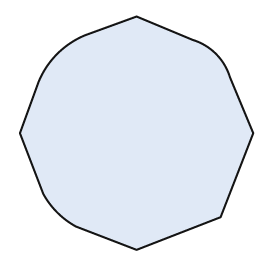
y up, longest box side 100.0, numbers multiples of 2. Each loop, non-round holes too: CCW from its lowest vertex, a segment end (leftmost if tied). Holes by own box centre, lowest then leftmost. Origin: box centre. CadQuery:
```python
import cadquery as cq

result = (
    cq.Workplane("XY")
    .moveTo(0.0, -50.0)
    .lineTo(36.0, -36.0)
    .lineTo(50.0, 0.0)
    .lineTo(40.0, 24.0)
    .threePointArc((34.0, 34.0), (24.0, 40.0))
    .lineTo(0.0, 50.0)
    .lineTo(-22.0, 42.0)
    .threePointArc((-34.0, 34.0), (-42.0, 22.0))
    .lineTo(-50.0, 0.0)
    .lineTo(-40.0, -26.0)
    .threePointArc((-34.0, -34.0), (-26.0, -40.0))
    .close()
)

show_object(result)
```